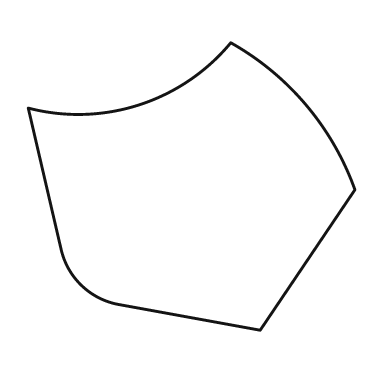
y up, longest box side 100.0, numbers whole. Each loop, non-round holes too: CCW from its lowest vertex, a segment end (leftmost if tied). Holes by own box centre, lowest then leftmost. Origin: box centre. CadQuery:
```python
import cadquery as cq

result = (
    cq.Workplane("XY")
    .moveTo(21.0, -44.0)
    .lineTo(50.0, -1.0)
    .threePointArc((35.0, 25.0), (12.0, 44.0))
    .threePointArc((-16.0, 25.0), (-50.0, 24.0))
    .lineTo(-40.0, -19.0)
    .threePointArc((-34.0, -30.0), (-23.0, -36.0))
    .close()
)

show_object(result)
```